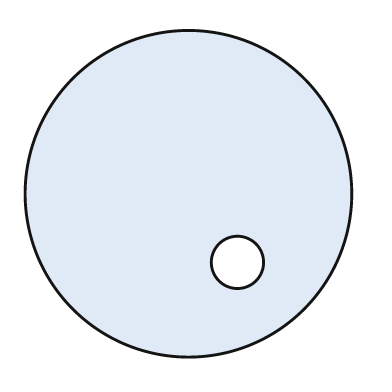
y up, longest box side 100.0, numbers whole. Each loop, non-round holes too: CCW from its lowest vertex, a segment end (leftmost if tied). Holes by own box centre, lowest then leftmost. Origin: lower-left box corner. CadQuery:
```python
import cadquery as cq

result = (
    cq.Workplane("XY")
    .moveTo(50.0, 50.0)
    .circle(50.0)
    .moveTo(65.0, 29.0)
    .circle(8.0)
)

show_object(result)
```